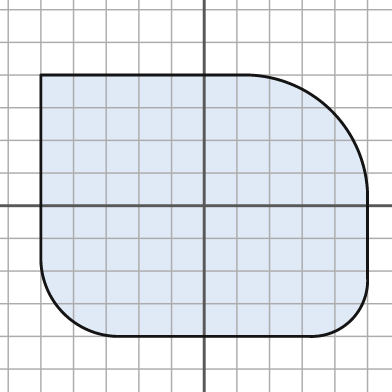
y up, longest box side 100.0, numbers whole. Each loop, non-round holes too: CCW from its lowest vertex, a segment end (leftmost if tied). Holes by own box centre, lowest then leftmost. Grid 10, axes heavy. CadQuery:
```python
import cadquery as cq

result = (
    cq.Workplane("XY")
    .moveTo(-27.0, -40.0)
    .lineTo(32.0, -40.0)
    .threePointArc((45.0, -35.0), (50.0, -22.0))
    .lineTo(50.0, 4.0)
    .threePointArc((39.0, 29.0), (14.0, 40.0))
    .lineTo(-50.0, 40.0)
    .lineTo(-50.0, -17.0)
    .threePointArc((-43.0, -33.0), (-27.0, -40.0))
    .close()
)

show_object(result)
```